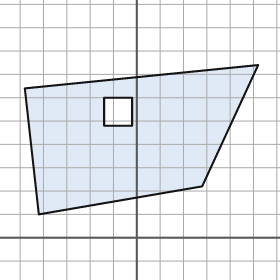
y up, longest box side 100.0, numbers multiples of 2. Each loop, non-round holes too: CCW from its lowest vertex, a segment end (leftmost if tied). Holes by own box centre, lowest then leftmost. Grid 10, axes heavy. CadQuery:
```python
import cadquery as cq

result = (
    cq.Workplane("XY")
    .moveTo(-42.0, 10.0)
    .lineTo(28.0, 22.0)
    .lineTo(52.0, 74.0)
    .lineTo(-48.0, 64.0)
    .close()
    .moveTo(-14.0, 48.0)
    .lineTo(-2.0, 48.0)
    .lineTo(-2.0, 60.0)
    .lineTo(-14.0, 60.0)
    .close()
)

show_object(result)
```